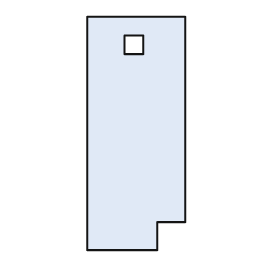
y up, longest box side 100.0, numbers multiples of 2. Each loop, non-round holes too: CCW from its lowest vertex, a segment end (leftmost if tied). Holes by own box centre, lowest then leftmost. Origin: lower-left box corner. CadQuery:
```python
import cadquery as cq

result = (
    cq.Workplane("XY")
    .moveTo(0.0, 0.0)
    .lineTo(30.0, 0.0)
    .lineTo(30.0, 12.0)
    .lineTo(42.0, 12.0)
    .lineTo(42.0, 100.0)
    .lineTo(0.0, 100.0)
    .close()
    .moveTo(16.0, 84.0)
    .lineTo(24.0, 84.0)
    .lineTo(24.0, 92.0)
    .lineTo(16.0, 92.0)
    .close()
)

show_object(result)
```